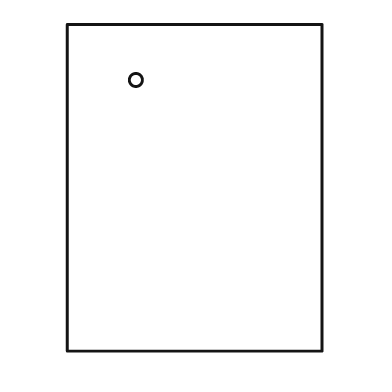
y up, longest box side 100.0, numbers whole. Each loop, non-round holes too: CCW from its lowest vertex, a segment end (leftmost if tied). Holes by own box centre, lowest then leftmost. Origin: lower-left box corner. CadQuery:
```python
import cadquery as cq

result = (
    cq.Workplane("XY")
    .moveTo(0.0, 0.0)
    .lineTo(78.0, 0.0)
    .lineTo(78.0, 100.0)
    .lineTo(0.0, 100.0)
    .close()
    .moveTo(21.0, 83.0)
    .circle(2.0)
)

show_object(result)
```